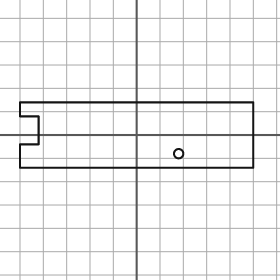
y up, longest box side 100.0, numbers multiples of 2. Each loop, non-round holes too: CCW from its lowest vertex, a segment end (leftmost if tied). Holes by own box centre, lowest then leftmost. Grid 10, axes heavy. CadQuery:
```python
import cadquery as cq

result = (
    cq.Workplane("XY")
    .moveTo(-50.0, -14.0)
    .lineTo(50.0, -14.0)
    .lineTo(50.0, 14.0)
    .lineTo(-50.0, 14.0)
    .lineTo(-50.0, 8.0)
    .lineTo(-42.0, 8.0)
    .lineTo(-42.0, -4.0)
    .lineTo(-50.0, -4.0)
    .close()
    .moveTo(18.0, -8.0)
    .circle(2.0)
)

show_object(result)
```